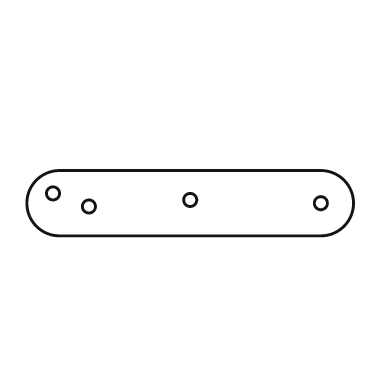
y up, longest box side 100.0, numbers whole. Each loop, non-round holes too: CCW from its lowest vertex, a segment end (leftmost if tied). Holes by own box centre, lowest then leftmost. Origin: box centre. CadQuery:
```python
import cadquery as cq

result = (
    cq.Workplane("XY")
    .moveTo(-40.0, -10.0)
    .lineTo(40.0, -10.0)
    .threePointArc((50.0, 0.0), (40.0, 10.0))
    .lineTo(-40.0, 10.0)
    .threePointArc((-50.0, 0.0), (-40.0, -10.0))
    .close()
    .moveTo(-31.0, -1.0)
    .circle(2.0)
    .moveTo(40.0, 0.0)
    .circle(2.0)
    .moveTo(0.0, 1.0)
    .circle(2.0)
    .moveTo(-42.0, 3.0)
    .circle(2.0)
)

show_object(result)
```